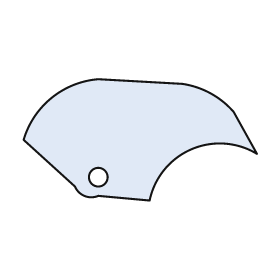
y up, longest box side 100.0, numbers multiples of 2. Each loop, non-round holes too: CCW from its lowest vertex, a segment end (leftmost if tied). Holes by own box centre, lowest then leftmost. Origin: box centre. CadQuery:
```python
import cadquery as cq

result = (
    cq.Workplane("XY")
    .moveTo(4.0, -26.0)
    .threePointArc((22.0, -4.0), (50.0, -6.0))
    .lineTo(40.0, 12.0)
    .threePointArc((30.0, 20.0), (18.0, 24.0))
    .lineTo(-18.0, 26.0)
    .threePointArc((-38.0, 18.0), (-50.0, 0.0))
    .lineTo(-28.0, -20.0)
    .threePointArc((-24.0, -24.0), (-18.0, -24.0))
    .close()
    .moveTo(-18.0, -16.0)
    .circle(4.0)
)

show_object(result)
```